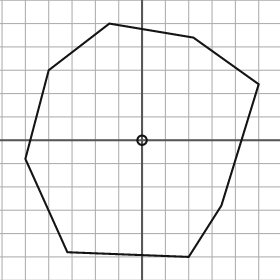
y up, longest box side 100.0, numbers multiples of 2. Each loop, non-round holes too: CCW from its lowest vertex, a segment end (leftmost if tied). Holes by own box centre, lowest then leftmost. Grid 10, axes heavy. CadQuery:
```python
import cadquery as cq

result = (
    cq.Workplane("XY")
    .moveTo(20.0, -50.0)
    .lineTo(34.0, -28.0)
    .lineTo(50.0, 24.0)
    .lineTo(22.0, 44.0)
    .lineTo(-14.0, 50.0)
    .lineTo(-40.0, 30.0)
    .lineTo(-50.0, -8.0)
    .lineTo(-32.0, -48.0)
    .close()
    .moveTo(0.0, 0.0)
    .circle(2.0)
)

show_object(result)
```